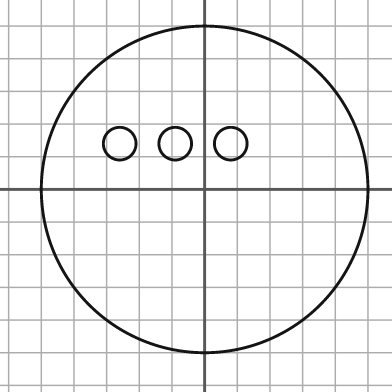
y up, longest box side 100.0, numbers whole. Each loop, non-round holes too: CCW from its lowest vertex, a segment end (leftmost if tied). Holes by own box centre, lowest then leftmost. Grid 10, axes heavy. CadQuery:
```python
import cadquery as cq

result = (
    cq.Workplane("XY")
    .moveTo(0.0, 0.0)
    .circle(50.0)
    .moveTo(-26.0, 14.0)
    .circle(5.0)
    .moveTo(-9.0, 14.0)
    .circle(5.0)
    .moveTo(8.0, 14.0)
    .circle(5.0)
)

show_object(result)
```